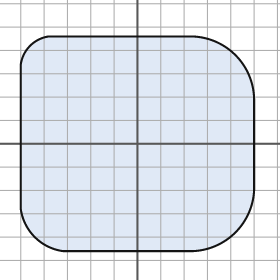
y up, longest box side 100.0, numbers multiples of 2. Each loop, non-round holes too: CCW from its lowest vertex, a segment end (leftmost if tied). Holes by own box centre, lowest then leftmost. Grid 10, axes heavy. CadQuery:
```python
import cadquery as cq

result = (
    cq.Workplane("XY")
    .moveTo(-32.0, -46.0)
    .lineTo(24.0, -46.0)
    .threePointArc((42.0, -38.0), (50.0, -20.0))
    .lineTo(50.0, 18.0)
    .threePointArc((42.0, 38.0), (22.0, 46.0))
    .lineTo(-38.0, 46.0)
    .threePointArc((-46.0, 42.0), (-50.0, 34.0))
    .lineTo(-50.0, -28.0)
    .threePointArc((-44.0, -40.0), (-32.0, -46.0))
    .close()
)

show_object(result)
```